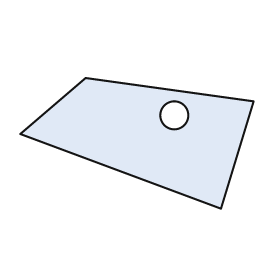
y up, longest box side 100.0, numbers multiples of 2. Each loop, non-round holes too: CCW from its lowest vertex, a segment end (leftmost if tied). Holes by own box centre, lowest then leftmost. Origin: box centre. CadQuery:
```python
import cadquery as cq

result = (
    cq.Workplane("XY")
    .moveTo(36.0, -28.0)
    .lineTo(50.0, 18.0)
    .lineTo(-22.0, 28.0)
    .lineTo(-50.0, 4.0)
    .close()
    .moveTo(16.0, 12.0)
    .circle(6.0)
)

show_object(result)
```